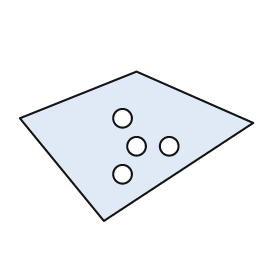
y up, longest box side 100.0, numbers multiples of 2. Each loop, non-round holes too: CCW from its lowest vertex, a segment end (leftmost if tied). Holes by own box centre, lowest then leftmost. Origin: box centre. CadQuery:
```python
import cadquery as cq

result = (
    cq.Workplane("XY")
    .moveTo(-14.0, -32.0)
    .lineTo(50.0, 10.0)
    .lineTo(0.0, 32.0)
    .lineTo(-50.0, 12.0)
    .close()
    .moveTo(-6.0, -12.0)
    .circle(4.0)
    .moveTo(0.0, 0.0)
    .circle(4.0)
    .moveTo(14.0, 0.0)
    .circle(4.0)
    .moveTo(-6.0, 12.0)
    .circle(4.0)
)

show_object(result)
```